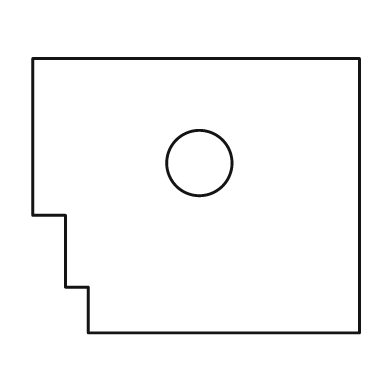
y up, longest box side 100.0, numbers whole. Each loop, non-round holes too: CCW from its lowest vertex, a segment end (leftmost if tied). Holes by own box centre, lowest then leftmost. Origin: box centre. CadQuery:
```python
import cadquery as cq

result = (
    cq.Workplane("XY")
    .moveTo(-33.0, -42.0)
    .lineTo(50.0, -42.0)
    .lineTo(50.0, 42.0)
    .lineTo(-50.0, 42.0)
    .lineTo(-50.0, -6.0)
    .lineTo(-40.0, -6.0)
    .lineTo(-40.0, -28.0)
    .lineTo(-33.0, -28.0)
    .close()
    .moveTo(1.0, 10.0)
    .circle(10.0)
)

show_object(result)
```